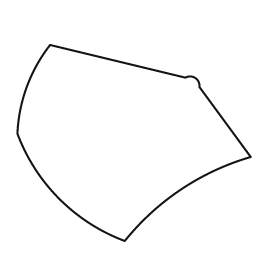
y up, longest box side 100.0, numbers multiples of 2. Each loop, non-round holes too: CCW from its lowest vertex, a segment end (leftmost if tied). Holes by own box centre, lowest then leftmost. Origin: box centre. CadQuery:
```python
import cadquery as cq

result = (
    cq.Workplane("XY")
    .moveTo(-4.0, -42.0)
    .threePointArc((20.0, -20.0), (50.0, -6.0))
    .lineTo(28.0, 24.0)
    .threePointArc((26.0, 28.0), (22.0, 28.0))
    .lineTo(-36.0, 42.0)
    .threePointArc((-46.0, 24.0), (-50.0, 4.0))
    .threePointArc((-32.0, -24.0), (-4.0, -42.0))
    .close()
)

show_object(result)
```